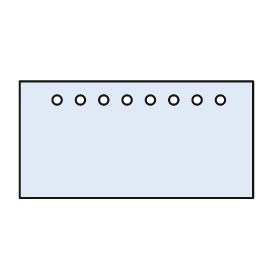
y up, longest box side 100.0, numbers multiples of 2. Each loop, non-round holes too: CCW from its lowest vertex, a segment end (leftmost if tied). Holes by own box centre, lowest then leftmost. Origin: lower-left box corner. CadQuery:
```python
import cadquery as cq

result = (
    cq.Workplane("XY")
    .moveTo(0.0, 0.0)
    .lineTo(100.0, 0.0)
    .lineTo(100.0, 50.0)
    .lineTo(0.0, 50.0)
    .close()
    .moveTo(16.0, 42.0)
    .circle(2.0)
    .moveTo(26.0, 42.0)
    .circle(2.0)
    .moveTo(36.0, 42.0)
    .circle(2.0)
    .moveTo(46.0, 42.0)
    .circle(2.0)
    .moveTo(56.0, 42.0)
    .circle(2.0)
    .moveTo(66.0, 42.0)
    .circle(2.0)
    .moveTo(76.0, 42.0)
    .circle(2.0)
    .moveTo(86.0, 42.0)
    .circle(2.0)
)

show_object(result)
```